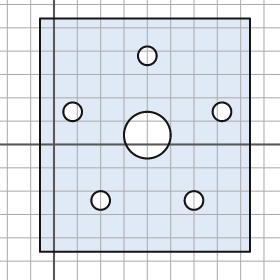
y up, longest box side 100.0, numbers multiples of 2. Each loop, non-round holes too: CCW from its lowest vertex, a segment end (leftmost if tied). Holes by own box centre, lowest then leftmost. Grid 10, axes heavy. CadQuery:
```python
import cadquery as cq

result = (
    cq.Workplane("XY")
    .moveTo(-6.0, -46.0)
    .lineTo(84.0, -46.0)
    .lineTo(84.0, 54.0)
    .lineTo(-6.0, 54.0)
    .close()
    .moveTo(20.0, -24.0)
    .circle(4.0)
    .moveTo(60.0, -24.0)
    .circle(4.0)
    .moveTo(40.0, 4.0)
    .circle(10.0)
    .moveTo(8.0, 14.0)
    .circle(4.0)
    .moveTo(72.0, 14.0)
    .circle(4.0)
    .moveTo(40.0, 38.0)
    .circle(4.0)
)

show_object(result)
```